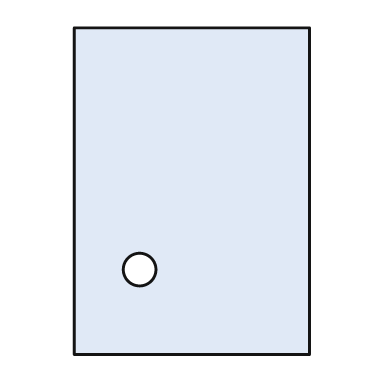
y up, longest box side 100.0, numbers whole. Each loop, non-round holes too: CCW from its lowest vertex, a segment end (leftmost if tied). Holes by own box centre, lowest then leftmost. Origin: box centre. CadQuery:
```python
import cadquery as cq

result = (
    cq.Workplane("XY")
    .moveTo(-36.0, -50.0)
    .lineTo(36.0, -50.0)
    .lineTo(36.0, 50.0)
    .lineTo(-36.0, 50.0)
    .close()
    .moveTo(-16.0, -24.0)
    .circle(5.0)
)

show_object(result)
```